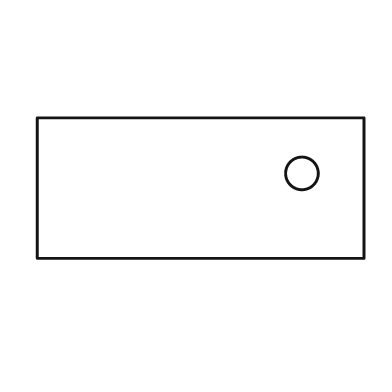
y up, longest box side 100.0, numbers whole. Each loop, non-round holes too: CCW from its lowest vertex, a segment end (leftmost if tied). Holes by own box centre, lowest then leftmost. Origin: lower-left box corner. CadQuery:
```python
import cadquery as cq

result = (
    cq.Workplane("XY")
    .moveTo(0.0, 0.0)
    .lineTo(100.0, 0.0)
    .lineTo(100.0, 43.0)
    .lineTo(0.0, 43.0)
    .close()
    .moveTo(81.0, 26.0)
    .circle(5.0)
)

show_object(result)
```